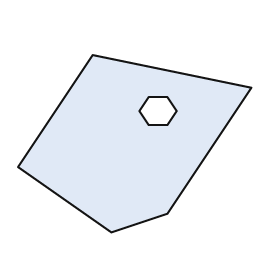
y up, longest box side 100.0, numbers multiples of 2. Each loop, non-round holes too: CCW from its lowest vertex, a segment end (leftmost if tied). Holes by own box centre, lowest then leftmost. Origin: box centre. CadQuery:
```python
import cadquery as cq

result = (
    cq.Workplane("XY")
    .moveTo(-10.0, -38.0)
    .lineTo(14.0, -30.0)
    .lineTo(50.0, 24.0)
    .lineTo(-18.0, 38.0)
    .lineTo(-50.0, -10.0)
    .close()
    .moveTo(6.0, 8.0)
    .lineTo(14.0, 8.0)
    .lineTo(18.0, 14.0)
    .lineTo(14.0, 20.0)
    .lineTo(6.0, 20.0)
    .lineTo(2.0, 14.0)
    .close()
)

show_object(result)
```